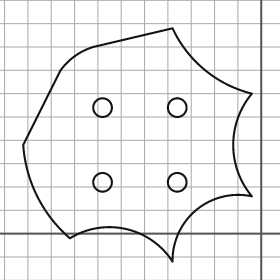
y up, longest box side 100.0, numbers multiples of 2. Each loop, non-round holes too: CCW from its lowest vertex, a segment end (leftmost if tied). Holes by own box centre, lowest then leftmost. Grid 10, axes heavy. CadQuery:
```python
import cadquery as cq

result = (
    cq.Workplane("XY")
    .moveTo(-38.0, -12.0)
    .threePointArc((-28.0, 10.0), (-4.0, 16.0))
    .threePointArc((-12.0, 38.0), (-4.0, 60.0))
    .threePointArc((-24.0, 70.0), (-38.0, 88.0))
    .lineTo(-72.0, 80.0)
    .threePointArc((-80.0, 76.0), (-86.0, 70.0))
    .lineTo(-102.0, 38.0)
    .threePointArc((-96.0, 16.0), (-82.0, -2.0))
    .threePointArc((-58.0, 2.0), (-38.0, -12.0))
    .close()
    .moveTo(-68.0, 22.0)
    .circle(4.0)
    .moveTo(-36.0, 22.0)
    .circle(4.0)
    .moveTo(-68.0, 54.0)
    .circle(4.0)
    .moveTo(-36.0, 54.0)
    .circle(4.0)
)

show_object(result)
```